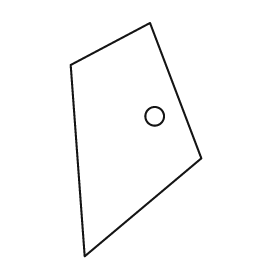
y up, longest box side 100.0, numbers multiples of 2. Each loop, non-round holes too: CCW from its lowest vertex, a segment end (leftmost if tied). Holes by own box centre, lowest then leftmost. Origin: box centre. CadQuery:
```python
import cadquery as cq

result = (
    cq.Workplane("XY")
    .moveTo(-22.0, -50.0)
    .lineTo(28.0, -8.0)
    .lineTo(6.0, 50.0)
    .lineTo(-28.0, 32.0)
    .close()
    .moveTo(8.0, 10.0)
    .circle(4.0)
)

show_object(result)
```